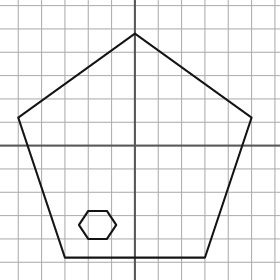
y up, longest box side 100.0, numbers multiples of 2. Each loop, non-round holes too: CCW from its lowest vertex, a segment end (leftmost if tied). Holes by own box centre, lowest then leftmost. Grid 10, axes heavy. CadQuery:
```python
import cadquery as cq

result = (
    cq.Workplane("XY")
    .moveTo(-30.0, -48.0)
    .lineTo(30.0, -48.0)
    .lineTo(50.0, 12.0)
    .lineTo(0.0, 48.0)
    .lineTo(-50.0, 12.0)
    .close()
    .moveTo(-20.0, -40.0)
    .lineTo(-12.0, -40.0)
    .lineTo(-8.0, -34.0)
    .lineTo(-12.0, -28.0)
    .lineTo(-20.0, -28.0)
    .lineTo(-24.0, -34.0)
    .close()
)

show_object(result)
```